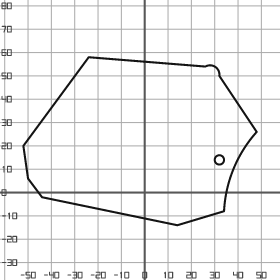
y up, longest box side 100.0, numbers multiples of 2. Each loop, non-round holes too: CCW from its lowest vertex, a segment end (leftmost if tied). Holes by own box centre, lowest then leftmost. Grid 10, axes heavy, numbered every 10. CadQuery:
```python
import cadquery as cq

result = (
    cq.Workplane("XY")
    .moveTo(14.0, -14.0)
    .lineTo(34.0, -8.0)
    .threePointArc((38.0, 10.0), (48.0, 26.0))
    .lineTo(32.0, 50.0)
    .threePointArc((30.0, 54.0), (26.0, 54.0))
    .lineTo(-24.0, 58.0)
    .lineTo(-52.0, 20.0)
    .lineTo(-50.0, 6.0)
    .lineTo(-44.0, -2.0)
    .close()
    .moveTo(32.0, 14.0)
    .circle(2.0)
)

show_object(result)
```